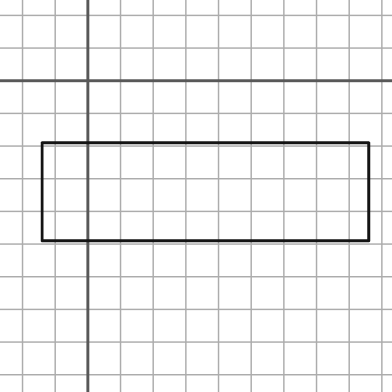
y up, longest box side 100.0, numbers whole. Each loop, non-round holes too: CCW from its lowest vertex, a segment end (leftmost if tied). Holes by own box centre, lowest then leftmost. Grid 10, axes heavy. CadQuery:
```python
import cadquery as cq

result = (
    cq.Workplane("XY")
    .moveTo(-14.0, -49.0)
    .lineTo(86.0, -49.0)
    .lineTo(86.0, -19.0)
    .lineTo(-14.0, -19.0)
    .close()
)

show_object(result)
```